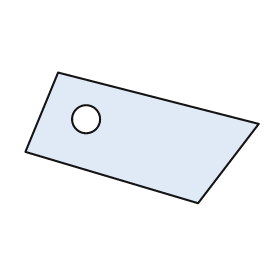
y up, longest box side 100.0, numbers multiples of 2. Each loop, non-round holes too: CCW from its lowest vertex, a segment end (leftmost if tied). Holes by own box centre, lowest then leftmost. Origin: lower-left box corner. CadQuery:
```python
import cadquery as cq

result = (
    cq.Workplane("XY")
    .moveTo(74.0, 0.0)
    .lineTo(100.0, 34.0)
    .lineTo(14.0, 56.0)
    .lineTo(0.0, 22.0)
    .close()
    .moveTo(26.0, 36.0)
    .circle(6.0)
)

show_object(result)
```